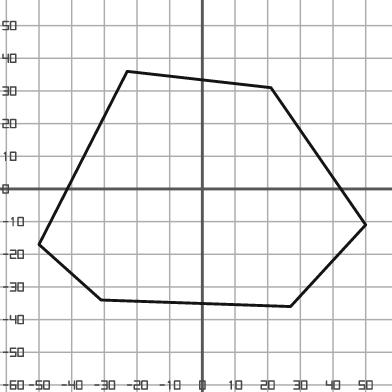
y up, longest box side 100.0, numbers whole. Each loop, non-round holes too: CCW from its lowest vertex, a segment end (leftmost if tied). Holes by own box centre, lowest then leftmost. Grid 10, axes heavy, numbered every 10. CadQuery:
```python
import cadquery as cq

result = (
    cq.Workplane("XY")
    .moveTo(27.0, -36.0)
    .lineTo(50.0, -11.0)
    .lineTo(21.0, 31.0)
    .lineTo(-23.0, 36.0)
    .lineTo(-50.0, -17.0)
    .lineTo(-31.0, -34.0)
    .close()
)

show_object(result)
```